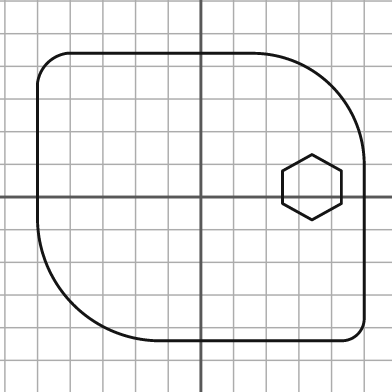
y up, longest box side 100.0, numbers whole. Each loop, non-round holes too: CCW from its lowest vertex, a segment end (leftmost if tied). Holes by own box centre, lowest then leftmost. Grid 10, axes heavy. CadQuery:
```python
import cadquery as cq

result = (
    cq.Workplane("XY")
    .moveTo(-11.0, -44.0)
    .lineTo(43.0, -44.0)
    .threePointArc((48.0, -42.0), (50.0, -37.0))
    .lineTo(50.0, 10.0)
    .threePointArc((40.0, 34.0), (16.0, 44.0))
    .lineTo(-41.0, 44.0)
    .threePointArc((-47.0, 41.0), (-50.0, 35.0))
    .lineTo(-50.0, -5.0)
    .threePointArc((-39.0, -33.0), (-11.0, -44.0))
    .close()
    .moveTo(34.0, -7.0)
    .lineTo(43.0, -2.0)
    .lineTo(43.0, 8.0)
    .lineTo(34.0, 13.0)
    .lineTo(25.0, 8.0)
    .lineTo(25.0, -2.0)
    .close()
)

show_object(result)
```